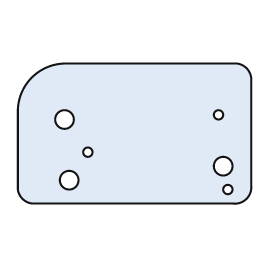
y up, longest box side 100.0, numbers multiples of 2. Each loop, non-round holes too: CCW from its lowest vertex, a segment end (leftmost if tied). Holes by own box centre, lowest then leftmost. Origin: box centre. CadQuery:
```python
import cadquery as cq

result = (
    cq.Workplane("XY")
    .moveTo(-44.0, -30.0)
    .lineTo(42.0, -30.0)
    .threePointArc((48.0, -28.0), (50.0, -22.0))
    .lineTo(50.0, 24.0)
    .threePointArc((48.0, 28.0), (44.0, 30.0))
    .lineTo(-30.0, 30.0)
    .threePointArc((-44.0, 24.0), (-50.0, 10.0))
    .lineTo(-50.0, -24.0)
    .threePointArc((-48.0, -28.0), (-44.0, -30.0))
    .close()
    .moveTo(40.0, -24.0)
    .circle(2.0)
    .moveTo(-28.0, -20.0)
    .circle(4.0)
    .moveTo(38.0, -14.0)
    .circle(4.0)
    .moveTo(-20.0, -8.0)
    .circle(2.0)
    .moveTo(-30.0, 6.0)
    .circle(4.0)
    .moveTo(36.0, 8.0)
    .circle(2.0)
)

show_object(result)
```